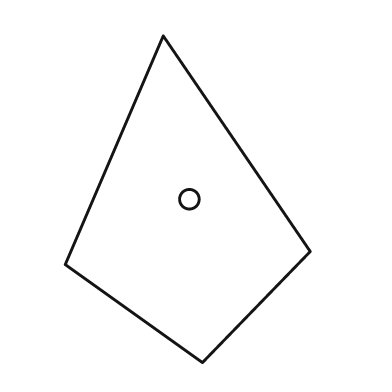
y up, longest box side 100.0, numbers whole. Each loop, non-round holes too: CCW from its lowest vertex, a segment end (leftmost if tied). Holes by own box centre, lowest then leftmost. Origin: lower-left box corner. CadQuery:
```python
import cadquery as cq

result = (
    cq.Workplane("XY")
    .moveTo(42.0, 0.0)
    .lineTo(75.0, 34.0)
    .lineTo(30.0, 100.0)
    .lineTo(0.0, 30.0)
    .close()
    .moveTo(38.0, 50.0)
    .circle(3.0)
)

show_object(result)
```